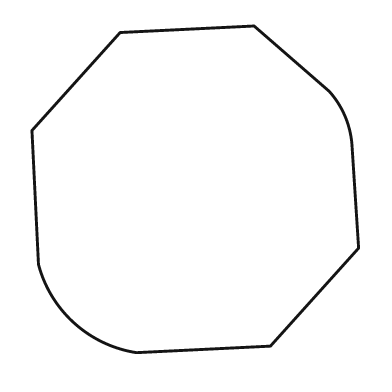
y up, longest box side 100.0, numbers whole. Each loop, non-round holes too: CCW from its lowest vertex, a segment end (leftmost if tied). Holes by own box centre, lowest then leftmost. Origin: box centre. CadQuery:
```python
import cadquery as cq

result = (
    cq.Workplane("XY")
    .moveTo(-18.0, -50.0)
    .lineTo(23.0, -48.0)
    .lineTo(50.0, -18.0)
    .lineTo(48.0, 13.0)
    .threePointArc((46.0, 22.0), (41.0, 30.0))
    .lineTo(18.0, 50.0)
    .lineTo(-23.0, 48.0)
    .lineTo(-50.0, 18.0)
    .lineTo(-48.0, -23.0)
    .threePointArc((-37.0, -41.0), (-18.0, -50.0))
    .close()
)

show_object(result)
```